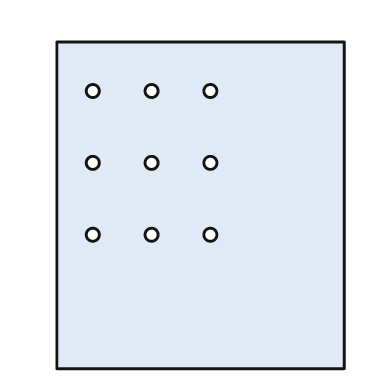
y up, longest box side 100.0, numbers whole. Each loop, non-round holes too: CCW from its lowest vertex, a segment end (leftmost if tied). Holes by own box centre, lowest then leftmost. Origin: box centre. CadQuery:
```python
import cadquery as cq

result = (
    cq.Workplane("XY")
    .moveTo(-44.0, -50.0)
    .lineTo(44.0, -50.0)
    .lineTo(44.0, 50.0)
    .lineTo(-44.0, 50.0)
    .close()
    .moveTo(-33.0, -9.0)
    .circle(2.0)
    .moveTo(-15.0, -9.0)
    .circle(2.0)
    .moveTo(3.0, -9.0)
    .circle(2.0)
    .moveTo(-33.0, 13.0)
    .circle(2.0)
    .moveTo(-15.0, 13.0)
    .circle(2.0)
    .moveTo(3.0, 13.0)
    .circle(2.0)
    .moveTo(-33.0, 35.0)
    .circle(2.0)
    .moveTo(-15.0, 35.0)
    .circle(2.0)
    .moveTo(3.0, 35.0)
    .circle(2.0)
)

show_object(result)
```